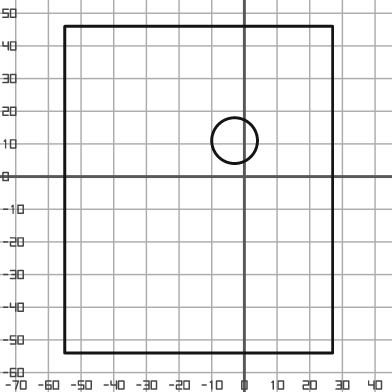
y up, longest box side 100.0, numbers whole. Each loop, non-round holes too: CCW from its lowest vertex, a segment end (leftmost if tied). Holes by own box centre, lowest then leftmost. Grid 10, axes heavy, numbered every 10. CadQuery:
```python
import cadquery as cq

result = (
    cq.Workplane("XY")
    .moveTo(-55.0, -54.0)
    .lineTo(27.0, -54.0)
    .lineTo(27.0, 46.0)
    .lineTo(-55.0, 46.0)
    .close()
    .moveTo(-3.0, 11.0)
    .circle(7.0)
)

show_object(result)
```